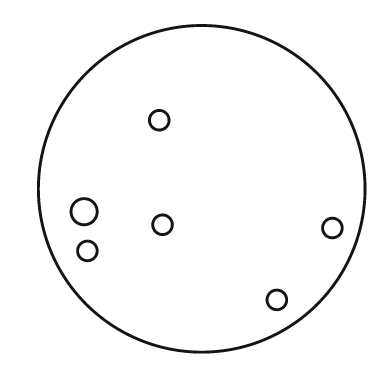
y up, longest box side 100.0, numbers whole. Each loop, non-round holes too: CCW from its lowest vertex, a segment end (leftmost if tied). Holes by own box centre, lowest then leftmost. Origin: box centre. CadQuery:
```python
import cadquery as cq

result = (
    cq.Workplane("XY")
    .moveTo(0.0, 0.0)
    .circle(50.0)
    .moveTo(23.0, -34.0)
    .circle(3.0)
    .moveTo(-35.0, -19.0)
    .circle(3.0)
    .moveTo(40.0, -12.0)
    .circle(3.0)
    .moveTo(-12.0, -11.0)
    .circle(3.0)
    .moveTo(-36.0, -7.0)
    .circle(4.0)
    .moveTo(-13.0, 21.0)
    .circle(3.0)
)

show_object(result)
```